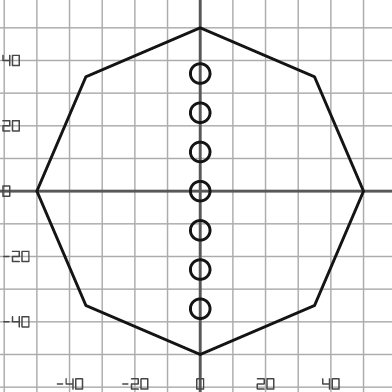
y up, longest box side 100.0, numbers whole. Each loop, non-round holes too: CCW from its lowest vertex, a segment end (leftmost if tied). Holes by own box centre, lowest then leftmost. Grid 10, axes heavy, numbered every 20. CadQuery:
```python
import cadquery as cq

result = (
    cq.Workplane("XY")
    .moveTo(0.0, -50.0)
    .lineTo(35.0, -35.0)
    .lineTo(50.0, 0.0)
    .lineTo(35.0, 35.0)
    .lineTo(0.0, 50.0)
    .lineTo(-35.0, 35.0)
    .lineTo(-50.0, 0.0)
    .lineTo(-35.0, -35.0)
    .close()
    .moveTo(0.0, -36.0)
    .circle(3.0)
    .moveTo(0.0, -24.0)
    .circle(3.0)
    .moveTo(0.0, -12.0)
    .circle(3.0)
    .moveTo(0.0, 0.0)
    .circle(3.0)
    .moveTo(0.0, 12.0)
    .circle(3.0)
    .moveTo(0.0, 24.0)
    .circle(3.0)
    .moveTo(0.0, 36.0)
    .circle(3.0)
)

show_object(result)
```